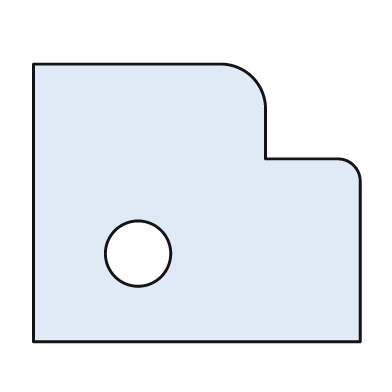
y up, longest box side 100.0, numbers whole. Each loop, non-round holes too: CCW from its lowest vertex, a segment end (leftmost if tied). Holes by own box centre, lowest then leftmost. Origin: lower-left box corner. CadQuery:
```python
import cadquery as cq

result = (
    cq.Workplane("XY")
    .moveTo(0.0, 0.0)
    .lineTo(100.0, 0.0)
    .lineTo(100.0, 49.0)
    .threePointArc((98.0, 54.0), (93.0, 56.0))
    .lineTo(71.0, 56.0)
    .lineTo(71.0, 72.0)
    .threePointArc((67.0, 81.0), (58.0, 85.0))
    .lineTo(0.0, 85.0)
    .close()
    .moveTo(32.0, 27.0)
    .circle(10.0)
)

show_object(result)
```